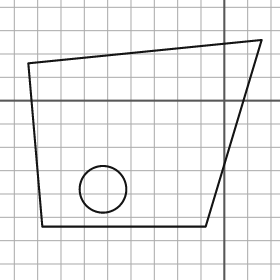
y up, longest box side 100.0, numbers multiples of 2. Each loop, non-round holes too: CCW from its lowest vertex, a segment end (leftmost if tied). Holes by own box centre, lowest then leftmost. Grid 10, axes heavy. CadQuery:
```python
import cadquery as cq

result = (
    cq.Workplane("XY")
    .moveTo(-78.0, -54.0)
    .lineTo(-8.0, -54.0)
    .lineTo(16.0, 26.0)
    .lineTo(-84.0, 16.0)
    .close()
    .moveTo(-52.0, -38.0)
    .circle(10.0)
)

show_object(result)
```